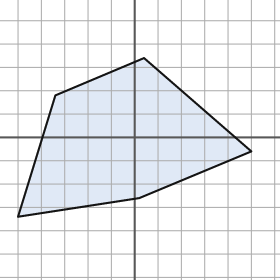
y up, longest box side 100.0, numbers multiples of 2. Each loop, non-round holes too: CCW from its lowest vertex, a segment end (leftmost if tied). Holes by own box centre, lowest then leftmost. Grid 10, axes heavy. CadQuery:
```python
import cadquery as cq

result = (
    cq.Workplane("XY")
    .moveTo(-50.0, -34.0)
    .lineTo(2.0, -26.0)
    .lineTo(50.0, -6.0)
    .lineTo(4.0, 34.0)
    .lineTo(-34.0, 18.0)
    .close()
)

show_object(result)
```